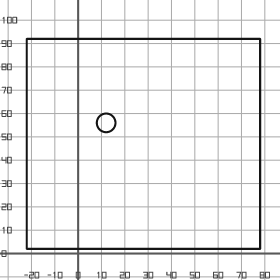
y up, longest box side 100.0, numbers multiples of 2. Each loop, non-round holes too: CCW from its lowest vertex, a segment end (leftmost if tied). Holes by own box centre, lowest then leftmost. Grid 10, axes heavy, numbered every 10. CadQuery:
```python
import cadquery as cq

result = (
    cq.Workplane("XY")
    .moveTo(-22.0, 2.0)
    .lineTo(78.0, 2.0)
    .lineTo(78.0, 92.0)
    .lineTo(-22.0, 92.0)
    .close()
    .moveTo(12.0, 56.0)
    .circle(4.0)
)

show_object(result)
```